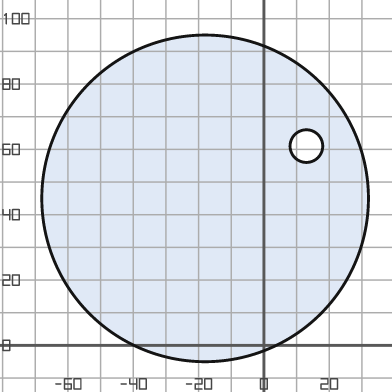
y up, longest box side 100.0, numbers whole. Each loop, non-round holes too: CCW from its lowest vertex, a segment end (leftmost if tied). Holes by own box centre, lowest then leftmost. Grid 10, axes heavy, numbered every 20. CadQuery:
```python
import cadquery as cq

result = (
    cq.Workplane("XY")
    .moveTo(-18.0, 45.0)
    .circle(50.0)
    .moveTo(13.0, 61.0)
    .circle(5.0)
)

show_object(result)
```